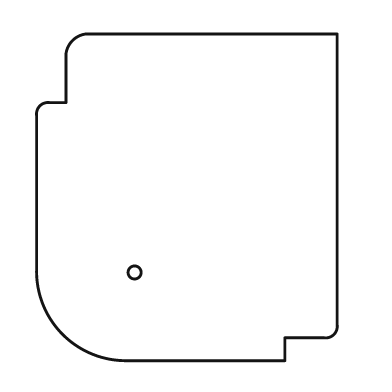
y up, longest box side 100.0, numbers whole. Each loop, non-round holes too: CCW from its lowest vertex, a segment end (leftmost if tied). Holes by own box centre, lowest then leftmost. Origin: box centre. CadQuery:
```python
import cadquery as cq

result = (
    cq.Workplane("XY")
    .moveTo(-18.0, -50.0)
    .lineTo(30.0, -50.0)
    .lineTo(30.0, -43.0)
    .lineTo(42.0, -43.0)
    .threePointArc((45.0, -42.0), (46.0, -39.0))
    .lineTo(46.0, 50.0)
    .lineTo(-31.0, 50.0)
    .threePointArc((-35.0, 48.0), (-37.0, 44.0))
    .lineTo(-37.0, 29.0)
    .lineTo(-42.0, 29.0)
    .threePointArc((-45.0, 28.0), (-46.0, 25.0))
    .lineTo(-46.0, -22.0)
    .threePointArc((-38.0, -42.0), (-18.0, -50.0))
    .close()
    .moveTo(-16.0, -23.0)
    .circle(2.0)
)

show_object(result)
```